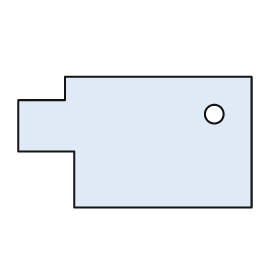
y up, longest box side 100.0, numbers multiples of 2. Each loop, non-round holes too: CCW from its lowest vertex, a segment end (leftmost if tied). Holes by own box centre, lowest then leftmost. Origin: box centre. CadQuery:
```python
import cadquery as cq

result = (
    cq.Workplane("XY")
    .moveTo(-26.0, -28.0)
    .lineTo(50.0, -28.0)
    .lineTo(50.0, 28.0)
    .lineTo(-30.0, 28.0)
    .lineTo(-30.0, 18.0)
    .lineTo(-50.0, 18.0)
    .lineTo(-50.0, -4.0)
    .lineTo(-26.0, -4.0)
    .close()
    .moveTo(34.0, 12.0)
    .circle(4.0)
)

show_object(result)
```